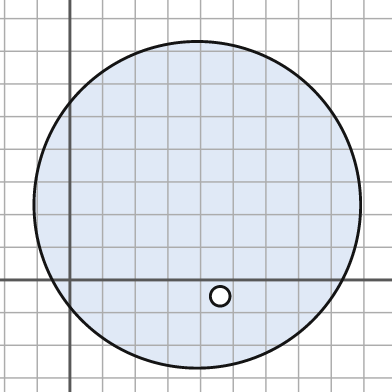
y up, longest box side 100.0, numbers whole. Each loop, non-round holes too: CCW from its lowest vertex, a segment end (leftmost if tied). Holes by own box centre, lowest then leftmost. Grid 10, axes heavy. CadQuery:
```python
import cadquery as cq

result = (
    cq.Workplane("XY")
    .moveTo(39.0, 23.0)
    .circle(50.0)
    .moveTo(46.0, -5.0)
    .circle(3.0)
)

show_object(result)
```